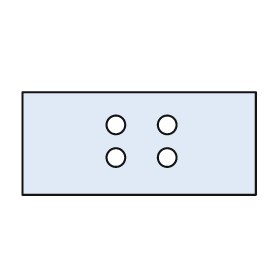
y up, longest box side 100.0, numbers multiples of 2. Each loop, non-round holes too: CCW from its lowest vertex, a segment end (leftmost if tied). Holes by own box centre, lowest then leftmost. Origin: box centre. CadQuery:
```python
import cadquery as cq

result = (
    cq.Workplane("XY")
    .moveTo(-50.0, -22.0)
    .lineTo(50.0, -22.0)
    .lineTo(50.0, 22.0)
    .lineTo(-50.0, 22.0)
    .close()
    .moveTo(-10.0, -6.0)
    .circle(4.0)
    .moveTo(12.0, -6.0)
    .circle(4.0)
    .moveTo(-10.0, 8.0)
    .circle(4.0)
    .moveTo(12.0, 8.0)
    .circle(4.0)
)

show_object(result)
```